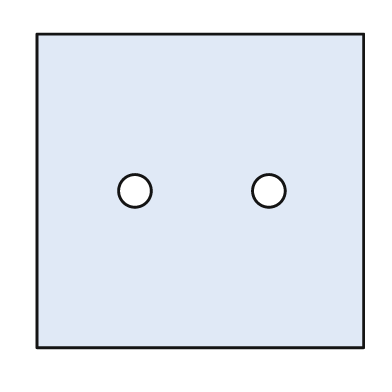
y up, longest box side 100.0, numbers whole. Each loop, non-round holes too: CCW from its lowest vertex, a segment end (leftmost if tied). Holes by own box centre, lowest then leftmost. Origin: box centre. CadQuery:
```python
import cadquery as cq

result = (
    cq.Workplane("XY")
    .moveTo(-50.0, -48.0)
    .lineTo(50.0, -48.0)
    .lineTo(50.0, 48.0)
    .lineTo(-50.0, 48.0)
    .close()
    .moveTo(-20.0, 0.0)
    .circle(5.0)
    .moveTo(21.0, 0.0)
    .circle(5.0)
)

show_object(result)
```